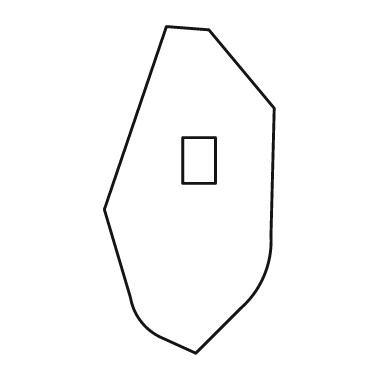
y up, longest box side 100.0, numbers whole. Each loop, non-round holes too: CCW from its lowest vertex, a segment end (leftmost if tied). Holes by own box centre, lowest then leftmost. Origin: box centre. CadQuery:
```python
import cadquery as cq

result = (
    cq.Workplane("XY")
    .moveTo(2.0, -50.0)
    .lineTo(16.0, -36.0)
    .threePointArc((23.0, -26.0), (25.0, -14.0))
    .lineTo(26.0, 25.0)
    .lineTo(6.0, 49.0)
    .lineTo(-7.0, 50.0)
    .lineTo(-26.0, -6.0)
    .lineTo(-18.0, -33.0)
    .threePointArc((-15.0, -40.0), (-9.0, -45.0))
    .close()
    .moveTo(-2.0, 2.0)
    .lineTo(8.0, 2.0)
    .lineTo(8.0, 16.0)
    .lineTo(-2.0, 16.0)
    .close()
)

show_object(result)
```